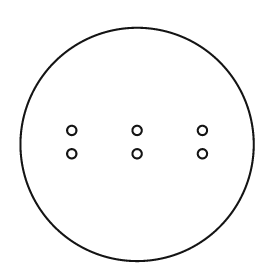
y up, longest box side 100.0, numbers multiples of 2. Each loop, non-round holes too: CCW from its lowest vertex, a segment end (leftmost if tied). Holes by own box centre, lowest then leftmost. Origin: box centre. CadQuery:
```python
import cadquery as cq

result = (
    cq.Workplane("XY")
    .moveTo(0.0, 0.0)
    .circle(50.0)
    .moveTo(-28.0, -4.0)
    .circle(2.0)
    .moveTo(0.0, -4.0)
    .circle(2.0)
    .moveTo(28.0, -4.0)
    .circle(2.0)
    .moveTo(-28.0, 6.0)
    .circle(2.0)
    .moveTo(0.0, 6.0)
    .circle(2.0)
    .moveTo(28.0, 6.0)
    .circle(2.0)
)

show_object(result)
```